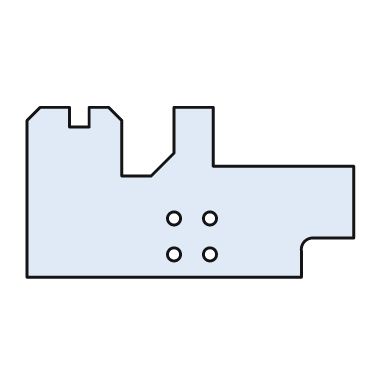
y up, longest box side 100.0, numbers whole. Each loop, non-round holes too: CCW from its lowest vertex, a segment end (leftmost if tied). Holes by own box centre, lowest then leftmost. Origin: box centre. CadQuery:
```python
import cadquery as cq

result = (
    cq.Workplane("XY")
    .moveTo(-50.0, -26.0)
    .lineTo(34.0, -26.0)
    .lineTo(34.0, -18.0)
    .threePointArc((35.0, -15.0), (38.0, -14.0))
    .lineTo(50.0, -14.0)
    .lineTo(50.0, 8.0)
    .lineTo(7.0, 8.0)
    .lineTo(7.0, 26.0)
    .lineTo(-5.0, 26.0)
    .lineTo(-5.0, 12.0)
    .lineTo(-12.0, 5.0)
    .lineTo(-21.0, 5.0)
    .lineTo(-21.0, 22.0)
    .lineTo(-25.0, 26.0)
    .lineTo(-31.0, 26.0)
    .lineTo(-31.0, 20.0)
    .lineTo(-37.0, 20.0)
    .lineTo(-37.0, 26.0)
    .lineTo(-46.0, 26.0)
    .lineTo(-50.0, 22.0)
    .close()
    .moveTo(-5.0, -19.0)
    .circle(2.0)
    .moveTo(6.0, -19.0)
    .circle(2.0)
    .moveTo(-5.0, -8.0)
    .circle(2.0)
    .moveTo(6.0, -8.0)
    .circle(2.0)
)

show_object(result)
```